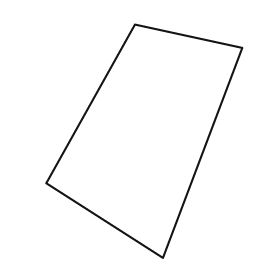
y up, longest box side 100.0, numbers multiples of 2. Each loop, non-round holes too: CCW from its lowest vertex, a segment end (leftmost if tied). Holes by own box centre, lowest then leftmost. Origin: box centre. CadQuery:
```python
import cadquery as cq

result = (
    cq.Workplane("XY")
    .moveTo(8.0, -50.0)
    .lineTo(42.0, 40.0)
    .lineTo(-4.0, 50.0)
    .lineTo(-42.0, -18.0)
    .close()
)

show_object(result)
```